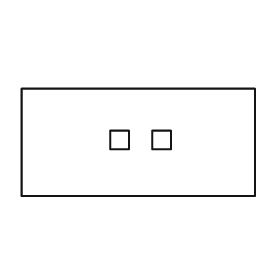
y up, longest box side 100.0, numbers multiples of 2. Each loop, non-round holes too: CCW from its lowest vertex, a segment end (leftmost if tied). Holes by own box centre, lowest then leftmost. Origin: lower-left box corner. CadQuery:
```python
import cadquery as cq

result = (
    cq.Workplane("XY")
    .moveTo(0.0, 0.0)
    .lineTo(100.0, 0.0)
    .lineTo(100.0, 46.0)
    .lineTo(0.0, 46.0)
    .close()
    .moveTo(38.0, 20.0)
    .lineTo(46.0, 20.0)
    .lineTo(46.0, 28.0)
    .lineTo(38.0, 28.0)
    .close()
    .moveTo(56.0, 20.0)
    .lineTo(64.0, 20.0)
    .lineTo(64.0, 28.0)
    .lineTo(56.0, 28.0)
    .close()
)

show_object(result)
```